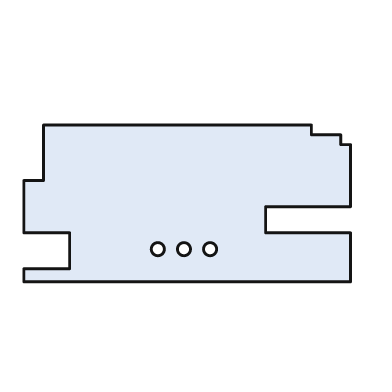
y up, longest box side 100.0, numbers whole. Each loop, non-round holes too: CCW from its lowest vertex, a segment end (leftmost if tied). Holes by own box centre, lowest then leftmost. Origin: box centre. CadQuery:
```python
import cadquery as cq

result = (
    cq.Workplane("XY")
    .moveTo(-50.0, -24.0)
    .lineTo(50.0, -24.0)
    .lineTo(50.0, -9.0)
    .lineTo(24.0, -9.0)
    .lineTo(24.0, -1.0)
    .lineTo(50.0, -1.0)
    .lineTo(50.0, 18.0)
    .lineTo(47.0, 18.0)
    .lineTo(47.0, 21.0)
    .lineTo(38.0, 21.0)
    .lineTo(38.0, 24.0)
    .lineTo(-44.0, 24.0)
    .lineTo(-44.0, 7.0)
    .lineTo(-50.0, 7.0)
    .lineTo(-50.0, -9.0)
    .lineTo(-36.0, -9.0)
    .lineTo(-36.0, -20.0)
    .lineTo(-50.0, -20.0)
    .close()
    .moveTo(-9.0, -14.0)
    .circle(2.0)
    .moveTo(-1.0, -14.0)
    .circle(2.0)
    .moveTo(7.0, -14.0)
    .circle(2.0)
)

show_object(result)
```